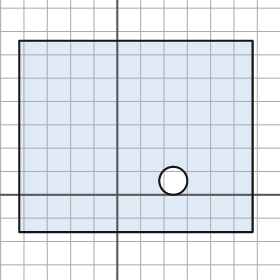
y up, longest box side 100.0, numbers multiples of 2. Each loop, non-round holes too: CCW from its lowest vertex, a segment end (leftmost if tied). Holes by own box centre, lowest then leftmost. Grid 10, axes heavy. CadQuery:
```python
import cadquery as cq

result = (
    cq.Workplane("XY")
    .moveTo(-42.0, -16.0)
    .lineTo(58.0, -16.0)
    .lineTo(58.0, 66.0)
    .lineTo(-42.0, 66.0)
    .close()
    .moveTo(24.0, 6.0)
    .circle(6.0)
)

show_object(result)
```